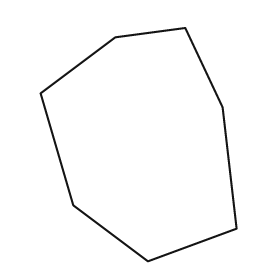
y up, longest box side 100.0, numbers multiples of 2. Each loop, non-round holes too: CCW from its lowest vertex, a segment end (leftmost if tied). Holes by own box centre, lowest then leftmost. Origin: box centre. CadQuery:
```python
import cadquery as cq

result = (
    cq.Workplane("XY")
    .moveTo(4.0, -50.0)
    .lineTo(42.0, -36.0)
    .lineTo(36.0, 16.0)
    .lineTo(20.0, 50.0)
    .lineTo(-10.0, 46.0)
    .lineTo(-42.0, 22.0)
    .lineTo(-28.0, -26.0)
    .close()
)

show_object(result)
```